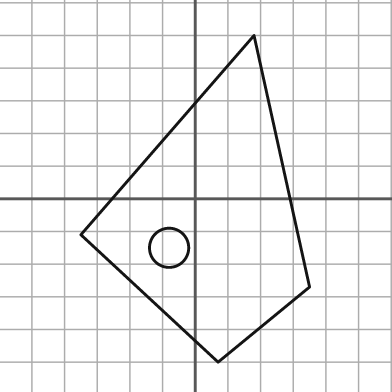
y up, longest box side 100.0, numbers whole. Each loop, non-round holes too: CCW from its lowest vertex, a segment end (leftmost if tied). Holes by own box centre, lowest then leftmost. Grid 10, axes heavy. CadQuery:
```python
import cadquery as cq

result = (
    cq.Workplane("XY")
    .moveTo(7.0, -50.0)
    .lineTo(35.0, -27.0)
    .lineTo(18.0, 50.0)
    .lineTo(-35.0, -11.0)
    .close()
    .moveTo(-8.0, -15.0)
    .circle(6.0)
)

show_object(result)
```